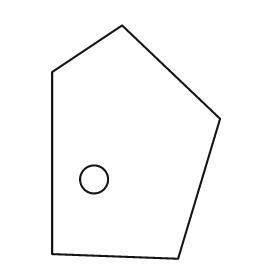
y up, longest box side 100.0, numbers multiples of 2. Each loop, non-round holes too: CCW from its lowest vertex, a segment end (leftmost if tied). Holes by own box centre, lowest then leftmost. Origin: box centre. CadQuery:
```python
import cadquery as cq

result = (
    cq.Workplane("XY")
    .moveTo(18.0, -50.0)
    .lineTo(36.0, 10.0)
    .lineTo(-6.0, 50.0)
    .lineTo(-36.0, 30.0)
    .lineTo(-36.0, -48.0)
    .close()
    .moveTo(-18.0, -16.0)
    .circle(6.0)
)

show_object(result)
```